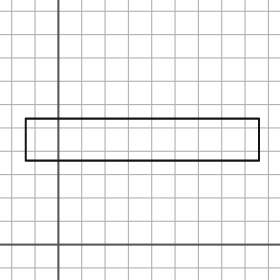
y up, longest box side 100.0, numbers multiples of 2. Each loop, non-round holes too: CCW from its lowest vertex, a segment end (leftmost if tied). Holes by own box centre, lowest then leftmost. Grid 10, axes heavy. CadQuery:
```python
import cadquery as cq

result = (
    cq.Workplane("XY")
    .moveTo(-14.0, 36.0)
    .lineTo(86.0, 36.0)
    .lineTo(86.0, 54.0)
    .lineTo(-14.0, 54.0)
    .close()
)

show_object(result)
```